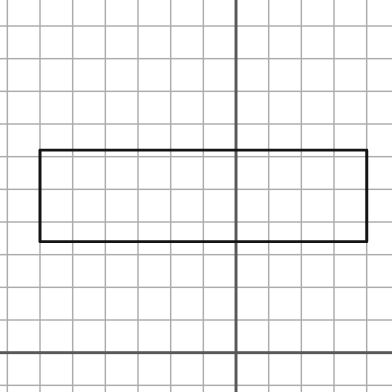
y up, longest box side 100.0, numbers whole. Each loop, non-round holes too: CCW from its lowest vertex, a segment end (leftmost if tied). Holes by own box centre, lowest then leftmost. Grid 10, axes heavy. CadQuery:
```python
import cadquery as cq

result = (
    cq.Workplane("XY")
    .moveTo(-60.0, 34.0)
    .lineTo(40.0, 34.0)
    .lineTo(40.0, 62.0)
    .lineTo(-60.0, 62.0)
    .close()
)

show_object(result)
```